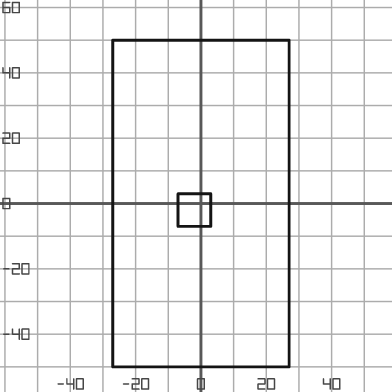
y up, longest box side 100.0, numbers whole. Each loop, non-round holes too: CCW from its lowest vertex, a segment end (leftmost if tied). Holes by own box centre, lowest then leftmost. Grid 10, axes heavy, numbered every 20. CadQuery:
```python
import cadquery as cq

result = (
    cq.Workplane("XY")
    .moveTo(-27.0, -50.0)
    .lineTo(27.0, -50.0)
    .lineTo(27.0, 50.0)
    .lineTo(-27.0, 50.0)
    .close()
    .moveTo(-7.0, -7.0)
    .lineTo(3.0, -7.0)
    .lineTo(3.0, 3.0)
    .lineTo(-7.0, 3.0)
    .close()
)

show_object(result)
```